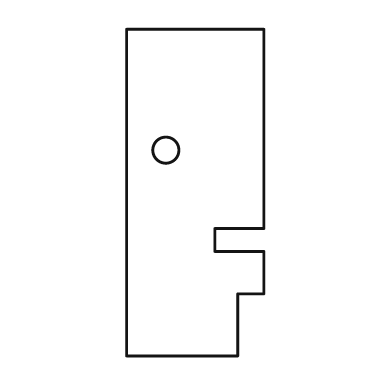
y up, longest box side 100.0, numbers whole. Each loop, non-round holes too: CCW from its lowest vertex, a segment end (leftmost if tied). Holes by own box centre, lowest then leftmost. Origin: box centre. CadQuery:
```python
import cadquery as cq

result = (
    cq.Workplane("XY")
    .moveTo(-21.0, -50.0)
    .lineTo(13.0, -50.0)
    .lineTo(13.0, -31.0)
    .lineTo(21.0, -31.0)
    .lineTo(21.0, -18.0)
    .lineTo(6.0, -18.0)
    .lineTo(6.0, -11.0)
    .lineTo(21.0, -11.0)
    .lineTo(21.0, 50.0)
    .lineTo(-21.0, 50.0)
    .close()
    .moveTo(-9.0, 13.0)
    .circle(4.0)
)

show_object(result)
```